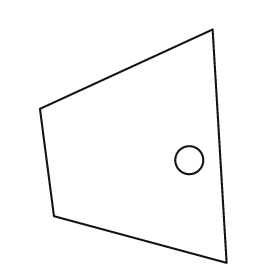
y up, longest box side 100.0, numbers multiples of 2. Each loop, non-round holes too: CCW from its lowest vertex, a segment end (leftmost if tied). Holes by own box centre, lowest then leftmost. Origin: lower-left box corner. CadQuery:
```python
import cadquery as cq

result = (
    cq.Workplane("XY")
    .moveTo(80.0, 0.0)
    .lineTo(74.0, 100.0)
    .lineTo(0.0, 66.0)
    .lineTo(6.0, 20.0)
    .close()
    .moveTo(64.0, 44.0)
    .circle(6.0)
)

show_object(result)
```